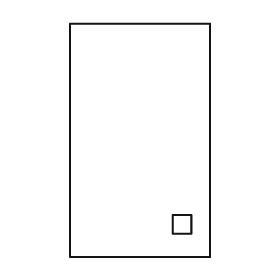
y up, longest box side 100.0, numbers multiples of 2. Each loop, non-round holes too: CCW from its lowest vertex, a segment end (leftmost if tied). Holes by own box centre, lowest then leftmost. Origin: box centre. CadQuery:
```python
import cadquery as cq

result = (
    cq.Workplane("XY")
    .moveTo(-30.0, -50.0)
    .lineTo(30.0, -50.0)
    .lineTo(30.0, 50.0)
    .lineTo(-30.0, 50.0)
    .close()
    .moveTo(14.0, -40.0)
    .lineTo(22.0, -40.0)
    .lineTo(22.0, -32.0)
    .lineTo(14.0, -32.0)
    .close()
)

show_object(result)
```